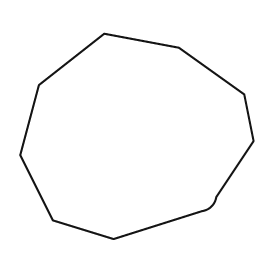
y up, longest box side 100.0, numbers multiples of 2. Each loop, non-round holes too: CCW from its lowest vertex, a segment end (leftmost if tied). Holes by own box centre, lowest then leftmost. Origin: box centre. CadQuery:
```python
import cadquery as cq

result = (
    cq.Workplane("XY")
    .moveTo(-10.0, -44.0)
    .lineTo(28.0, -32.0)
    .threePointArc((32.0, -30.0), (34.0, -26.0))
    .lineTo(50.0, -2.0)
    .lineTo(46.0, 18.0)
    .lineTo(18.0, 38.0)
    .lineTo(-14.0, 44.0)
    .lineTo(-42.0, 22.0)
    .lineTo(-50.0, -8.0)
    .lineTo(-36.0, -36.0)
    .close()
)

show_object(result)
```